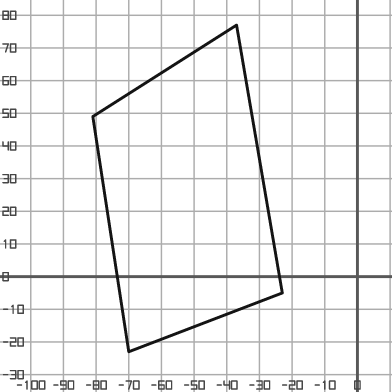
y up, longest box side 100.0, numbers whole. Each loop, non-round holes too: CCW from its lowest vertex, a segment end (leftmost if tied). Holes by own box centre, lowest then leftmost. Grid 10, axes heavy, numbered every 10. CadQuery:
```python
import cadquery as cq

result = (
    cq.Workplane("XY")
    .moveTo(-70.0, -23.0)
    .lineTo(-23.0, -5.0)
    .lineTo(-37.0, 77.0)
    .lineTo(-81.0, 49.0)
    .close()
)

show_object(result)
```